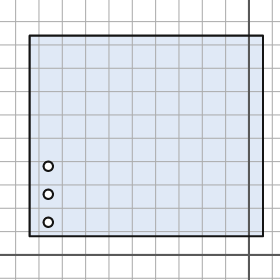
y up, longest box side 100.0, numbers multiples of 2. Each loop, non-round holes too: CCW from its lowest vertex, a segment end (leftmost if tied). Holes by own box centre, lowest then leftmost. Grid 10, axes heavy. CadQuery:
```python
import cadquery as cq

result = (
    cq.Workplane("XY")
    .moveTo(-94.0, 8.0)
    .lineTo(6.0, 8.0)
    .lineTo(6.0, 94.0)
    .lineTo(-94.0, 94.0)
    .close()
    .moveTo(-86.0, 14.0)
    .circle(2.0)
    .moveTo(-86.0, 26.0)
    .circle(2.0)
    .moveTo(-86.0, 38.0)
    .circle(2.0)
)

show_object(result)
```